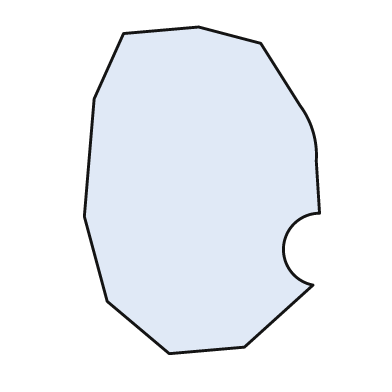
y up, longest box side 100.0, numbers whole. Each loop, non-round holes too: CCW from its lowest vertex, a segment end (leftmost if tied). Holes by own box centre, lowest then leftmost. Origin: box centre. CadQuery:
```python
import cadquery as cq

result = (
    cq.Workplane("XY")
    .moveTo(-10.0, -50.0)
    .lineTo(13.0, -48.0)
    .lineTo(34.0, -29.0)
    .threePointArc((25.0, -17.0), (36.0, -7.0))
    .lineTo(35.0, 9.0)
    .threePointArc((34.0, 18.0), (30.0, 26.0))
    .lineTo(18.0, 45.0)
    .lineTo(-1.0, 50.0)
    .lineTo(-24.0, 48.0)
    .lineTo(-33.0, 28.0)
    .lineTo(-36.0, -8.0)
    .lineTo(-29.0, -34.0)
    .close()
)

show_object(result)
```